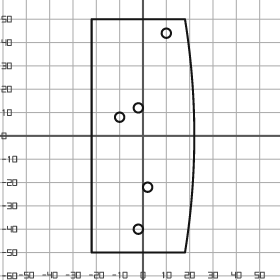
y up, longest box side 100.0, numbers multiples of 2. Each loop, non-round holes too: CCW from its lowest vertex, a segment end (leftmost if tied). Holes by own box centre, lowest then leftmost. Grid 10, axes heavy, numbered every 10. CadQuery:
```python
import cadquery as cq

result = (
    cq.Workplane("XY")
    .moveTo(-22.0, -50.0)
    .lineTo(18.0, -50.0)
    .threePointArc((22.0, 0.0), (18.0, 50.0))
    .lineTo(-22.0, 50.0)
    .close()
    .moveTo(-2.0, -40.0)
    .circle(2.0)
    .moveTo(2.0, -22.0)
    .circle(2.0)
    .moveTo(-10.0, 8.0)
    .circle(2.0)
    .moveTo(-2.0, 12.0)
    .circle(2.0)
    .moveTo(10.0, 44.0)
    .circle(2.0)
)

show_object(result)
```